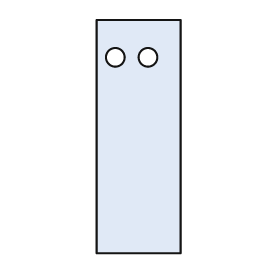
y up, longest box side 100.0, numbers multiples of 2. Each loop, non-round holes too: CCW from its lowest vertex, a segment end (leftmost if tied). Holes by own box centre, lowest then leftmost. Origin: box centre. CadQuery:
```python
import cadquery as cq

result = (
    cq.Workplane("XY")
    .moveTo(-18.0, -50.0)
    .lineTo(18.0, -50.0)
    .lineTo(18.0, 50.0)
    .lineTo(-18.0, 50.0)
    .close()
    .moveTo(-10.0, 34.0)
    .circle(4.0)
    .moveTo(4.0, 34.0)
    .circle(4.0)
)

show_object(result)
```